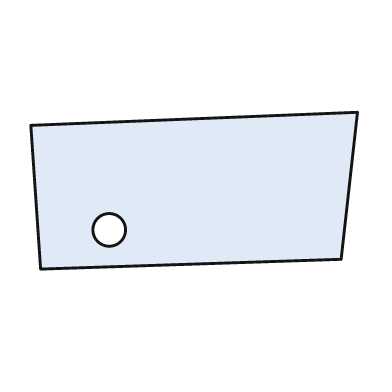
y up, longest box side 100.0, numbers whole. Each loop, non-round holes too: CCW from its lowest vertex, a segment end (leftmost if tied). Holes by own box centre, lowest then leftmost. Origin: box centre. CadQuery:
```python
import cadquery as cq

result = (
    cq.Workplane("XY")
    .moveTo(-47.0, -24.0)
    .lineTo(45.0, -21.0)
    .lineTo(50.0, 24.0)
    .lineTo(-50.0, 20.0)
    .close()
    .moveTo(-26.0, -12.0)
    .circle(5.0)
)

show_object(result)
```